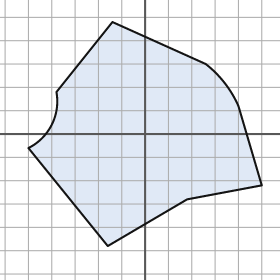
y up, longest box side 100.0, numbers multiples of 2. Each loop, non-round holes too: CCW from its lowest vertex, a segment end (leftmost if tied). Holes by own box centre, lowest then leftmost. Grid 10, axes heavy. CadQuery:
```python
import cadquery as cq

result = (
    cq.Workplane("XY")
    .moveTo(-16.0, -48.0)
    .lineTo(18.0, -28.0)
    .lineTo(50.0, -22.0)
    .lineTo(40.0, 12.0)
    .threePointArc((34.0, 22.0), (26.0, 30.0))
    .lineTo(-14.0, 48.0)
    .lineTo(-38.0, 18.0)
    .threePointArc((-40.0, 4.0), (-50.0, -6.0))
    .close()
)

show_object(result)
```